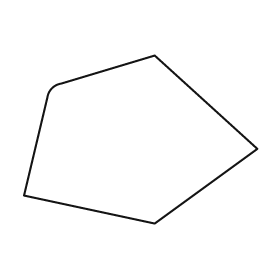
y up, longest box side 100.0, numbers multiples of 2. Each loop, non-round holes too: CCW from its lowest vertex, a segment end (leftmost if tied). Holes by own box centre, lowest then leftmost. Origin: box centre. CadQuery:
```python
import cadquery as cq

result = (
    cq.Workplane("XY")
    .moveTo(6.0, -36.0)
    .lineTo(50.0, -4.0)
    .lineTo(6.0, 36.0)
    .lineTo(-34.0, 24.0)
    .threePointArc((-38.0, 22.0), (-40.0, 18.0))
    .lineTo(-50.0, -24.0)
    .close()
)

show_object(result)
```